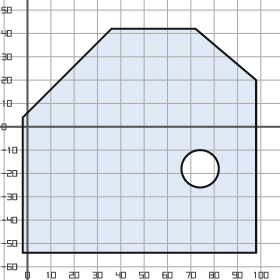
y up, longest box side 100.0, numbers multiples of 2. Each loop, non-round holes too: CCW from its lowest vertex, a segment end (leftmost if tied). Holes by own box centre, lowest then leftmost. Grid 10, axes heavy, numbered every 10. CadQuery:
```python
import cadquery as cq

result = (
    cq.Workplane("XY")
    .moveTo(-2.0, -54.0)
    .lineTo(98.0, -54.0)
    .lineTo(98.0, 20.0)
    .lineTo(72.0, 42.0)
    .lineTo(36.0, 42.0)
    .lineTo(-2.0, 4.0)
    .close()
    .moveTo(74.0, -18.0)
    .circle(8.0)
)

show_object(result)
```